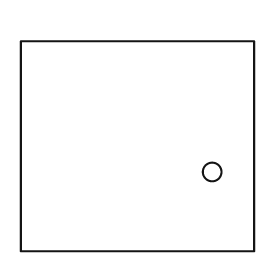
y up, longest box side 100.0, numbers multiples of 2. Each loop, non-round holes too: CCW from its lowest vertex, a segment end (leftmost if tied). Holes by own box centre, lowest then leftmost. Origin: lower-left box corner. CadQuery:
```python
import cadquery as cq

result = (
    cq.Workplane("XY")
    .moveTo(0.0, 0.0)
    .lineTo(100.0, 0.0)
    .lineTo(100.0, 90.0)
    .lineTo(0.0, 90.0)
    .close()
    .moveTo(82.0, 34.0)
    .circle(4.0)
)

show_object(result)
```